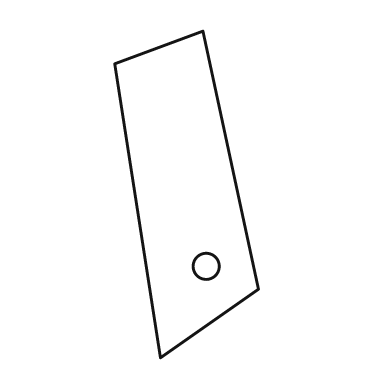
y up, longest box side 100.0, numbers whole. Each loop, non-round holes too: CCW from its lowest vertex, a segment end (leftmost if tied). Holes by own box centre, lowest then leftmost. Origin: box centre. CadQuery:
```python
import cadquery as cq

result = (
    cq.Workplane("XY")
    .moveTo(-8.0, -50.0)
    .lineTo(22.0, -29.0)
    .lineTo(5.0, 50.0)
    .lineTo(-22.0, 40.0)
    .close()
    .moveTo(6.0, -22.0)
    .circle(4.0)
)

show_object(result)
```